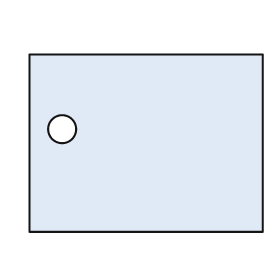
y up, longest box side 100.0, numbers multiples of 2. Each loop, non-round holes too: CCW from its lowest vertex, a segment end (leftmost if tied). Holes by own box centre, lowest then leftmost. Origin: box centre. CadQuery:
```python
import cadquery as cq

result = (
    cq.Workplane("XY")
    .moveTo(-50.0, -38.0)
    .lineTo(50.0, -38.0)
    .lineTo(50.0, 38.0)
    .lineTo(-50.0, 38.0)
    .close()
    .moveTo(-36.0, 6.0)
    .circle(6.0)
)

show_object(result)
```